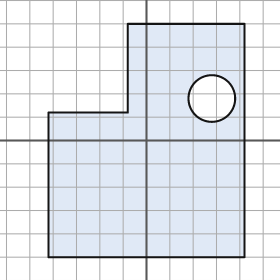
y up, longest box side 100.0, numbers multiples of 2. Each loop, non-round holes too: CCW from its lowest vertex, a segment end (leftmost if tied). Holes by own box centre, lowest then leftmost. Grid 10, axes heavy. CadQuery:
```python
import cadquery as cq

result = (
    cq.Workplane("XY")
    .moveTo(-42.0, -50.0)
    .lineTo(42.0, -50.0)
    .lineTo(42.0, 50.0)
    .lineTo(-8.0, 50.0)
    .lineTo(-8.0, 12.0)
    .lineTo(-42.0, 12.0)
    .close()
    .moveTo(28.0, 18.0)
    .circle(10.0)
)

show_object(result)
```